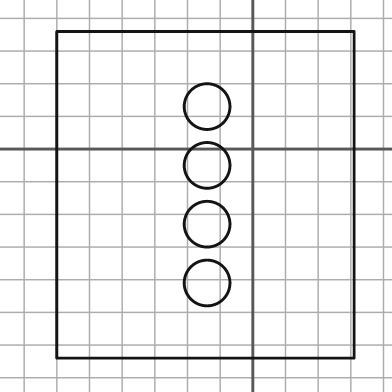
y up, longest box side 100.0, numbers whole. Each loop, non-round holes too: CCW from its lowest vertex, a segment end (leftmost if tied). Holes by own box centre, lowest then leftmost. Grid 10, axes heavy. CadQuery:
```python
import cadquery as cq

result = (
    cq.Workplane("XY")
    .moveTo(-60.0, -64.0)
    .lineTo(31.0, -64.0)
    .lineTo(31.0, 36.0)
    .lineTo(-60.0, 36.0)
    .close()
    .moveTo(-14.0, -41.0)
    .circle(7.0)
    .moveTo(-14.0, -23.0)
    .circle(7.0)
    .moveTo(-14.0, -5.0)
    .circle(7.0)
    .moveTo(-14.0, 13.0)
    .circle(7.0)
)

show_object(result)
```